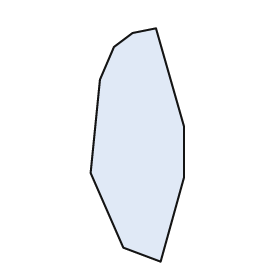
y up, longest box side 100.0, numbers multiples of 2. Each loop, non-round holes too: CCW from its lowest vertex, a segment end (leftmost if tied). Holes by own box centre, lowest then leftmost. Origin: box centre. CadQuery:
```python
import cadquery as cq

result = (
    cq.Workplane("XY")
    .moveTo(10.0, -50.0)
    .lineTo(20.0, -14.0)
    .lineTo(20.0, 8.0)
    .lineTo(8.0, 50.0)
    .lineTo(-2.0, 48.0)
    .lineTo(-10.0, 42.0)
    .lineTo(-16.0, 28.0)
    .lineTo(-20.0, -12.0)
    .lineTo(-6.0, -44.0)
    .close()
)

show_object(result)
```